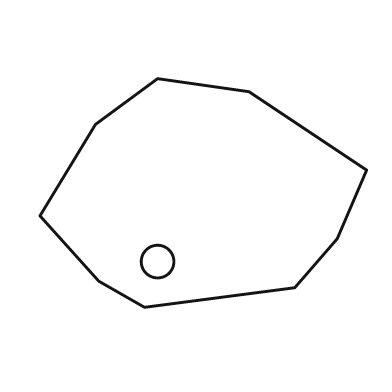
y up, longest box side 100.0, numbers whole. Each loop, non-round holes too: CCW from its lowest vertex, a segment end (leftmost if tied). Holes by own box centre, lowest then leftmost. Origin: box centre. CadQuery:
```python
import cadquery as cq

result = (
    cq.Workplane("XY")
    .moveTo(-18.0, -35.0)
    .lineTo(28.0, -29.0)
    .lineTo(41.0, -14.0)
    .lineTo(50.0, 7.0)
    .lineTo(14.0, 31.0)
    .lineTo(-14.0, 35.0)
    .lineTo(-33.0, 21.0)
    .lineTo(-50.0, -7.0)
    .lineTo(-32.0, -27.0)
    .close()
    .moveTo(-14.0, -21.0)
    .circle(5.0)
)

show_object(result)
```